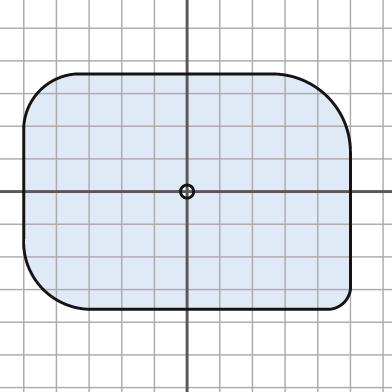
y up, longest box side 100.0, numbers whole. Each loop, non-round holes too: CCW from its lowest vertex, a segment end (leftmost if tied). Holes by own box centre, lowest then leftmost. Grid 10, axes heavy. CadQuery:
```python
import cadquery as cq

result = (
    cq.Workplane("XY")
    .moveTo(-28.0, -36.0)
    .lineTo(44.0, -36.0)
    .threePointArc((48.0, -34.0), (50.0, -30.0))
    .lineTo(50.0, 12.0)
    .threePointArc((43.0, 29.0), (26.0, 36.0))
    .lineTo(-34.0, 36.0)
    .threePointArc((-45.0, 31.0), (-50.0, 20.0))
    .lineTo(-50.0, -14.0)
    .threePointArc((-44.0, -30.0), (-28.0, -36.0))
    .close()
    .moveTo(0.0, 0.0)
    .circle(2.0)
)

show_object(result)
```